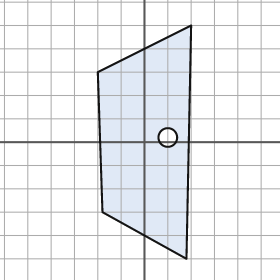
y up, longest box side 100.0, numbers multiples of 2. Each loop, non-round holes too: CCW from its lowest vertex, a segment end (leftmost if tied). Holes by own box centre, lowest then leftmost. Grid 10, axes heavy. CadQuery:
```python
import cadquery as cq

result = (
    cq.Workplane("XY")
    .moveTo(18.0, -50.0)
    .lineTo(20.0, 50.0)
    .lineTo(-20.0, 30.0)
    .lineTo(-18.0, -30.0)
    .close()
    .moveTo(10.0, 2.0)
    .circle(4.0)
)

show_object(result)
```